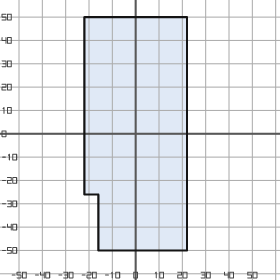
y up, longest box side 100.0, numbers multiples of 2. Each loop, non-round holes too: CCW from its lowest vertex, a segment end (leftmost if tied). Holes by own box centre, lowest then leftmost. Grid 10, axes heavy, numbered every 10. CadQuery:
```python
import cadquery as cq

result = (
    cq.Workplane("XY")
    .moveTo(-16.0, -50.0)
    .lineTo(22.0, -50.0)
    .lineTo(22.0, 50.0)
    .lineTo(-22.0, 50.0)
    .lineTo(-22.0, -26.0)
    .lineTo(-16.0, -26.0)
    .close()
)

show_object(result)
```